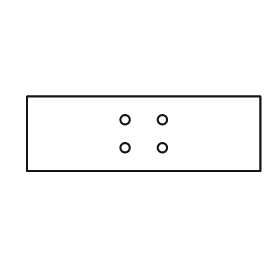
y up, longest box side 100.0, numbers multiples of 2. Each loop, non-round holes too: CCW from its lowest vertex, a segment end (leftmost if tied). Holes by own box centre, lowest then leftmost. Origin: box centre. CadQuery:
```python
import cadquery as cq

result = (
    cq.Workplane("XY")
    .moveTo(-50.0, -16.0)
    .lineTo(50.0, -16.0)
    .lineTo(50.0, 16.0)
    .lineTo(-50.0, 16.0)
    .close()
    .moveTo(-8.0, -6.0)
    .circle(2.0)
    .moveTo(8.0, -6.0)
    .circle(2.0)
    .moveTo(-8.0, 6.0)
    .circle(2.0)
    .moveTo(8.0, 6.0)
    .circle(2.0)
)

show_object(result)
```